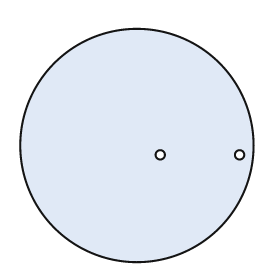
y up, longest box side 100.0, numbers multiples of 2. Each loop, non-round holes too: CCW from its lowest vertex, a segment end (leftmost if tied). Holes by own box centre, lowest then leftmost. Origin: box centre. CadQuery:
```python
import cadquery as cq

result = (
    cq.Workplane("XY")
    .moveTo(0.0, 0.0)
    .circle(50.0)
    .moveTo(10.0, -4.0)
    .circle(2.0)
    .moveTo(44.0, -4.0)
    .circle(2.0)
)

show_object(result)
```